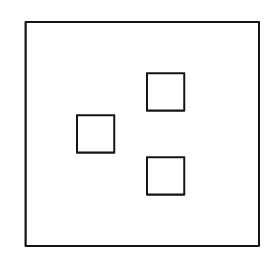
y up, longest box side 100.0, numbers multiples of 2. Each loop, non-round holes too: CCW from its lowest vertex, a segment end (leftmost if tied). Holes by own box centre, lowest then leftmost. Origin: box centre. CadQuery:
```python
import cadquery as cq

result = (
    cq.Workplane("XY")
    .moveTo(-50.0, -48.0)
    .lineTo(50.0, -48.0)
    .lineTo(50.0, 48.0)
    .lineTo(-50.0, 48.0)
    .close()
    .moveTo(2.0, -26.0)
    .lineTo(18.0, -26.0)
    .lineTo(18.0, -10.0)
    .lineTo(2.0, -10.0)
    .close()
    .moveTo(-28.0, -8.0)
    .lineTo(-12.0, -8.0)
    .lineTo(-12.0, 8.0)
    .lineTo(-28.0, 8.0)
    .close()
    .moveTo(2.0, 10.0)
    .lineTo(18.0, 10.0)
    .lineTo(18.0, 26.0)
    .lineTo(2.0, 26.0)
    .close()
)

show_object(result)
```